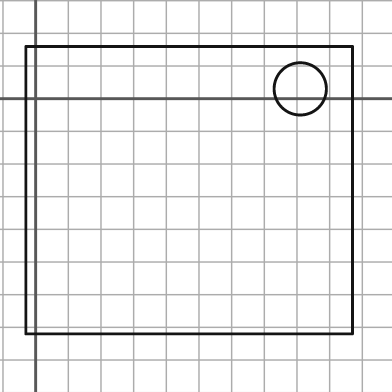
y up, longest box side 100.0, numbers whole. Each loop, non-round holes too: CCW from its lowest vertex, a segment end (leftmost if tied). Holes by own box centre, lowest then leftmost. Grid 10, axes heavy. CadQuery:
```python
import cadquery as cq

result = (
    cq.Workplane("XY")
    .moveTo(-3.0, -72.0)
    .lineTo(97.0, -72.0)
    .lineTo(97.0, 16.0)
    .lineTo(-3.0, 16.0)
    .close()
    .moveTo(81.0, 3.0)
    .circle(8.0)
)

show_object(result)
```